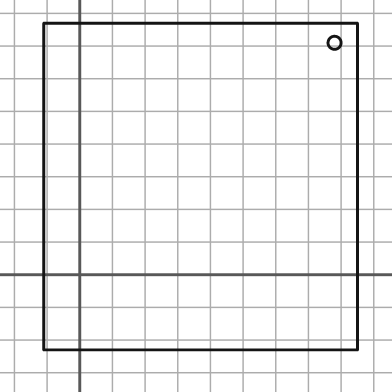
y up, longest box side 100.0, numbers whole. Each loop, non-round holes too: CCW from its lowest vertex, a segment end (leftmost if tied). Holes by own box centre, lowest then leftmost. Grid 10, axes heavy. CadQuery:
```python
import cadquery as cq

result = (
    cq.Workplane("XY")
    .moveTo(-11.0, -23.0)
    .lineTo(85.0, -23.0)
    .lineTo(85.0, 77.0)
    .lineTo(-11.0, 77.0)
    .close()
    .moveTo(78.0, 71.0)
    .circle(2.0)
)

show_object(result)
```